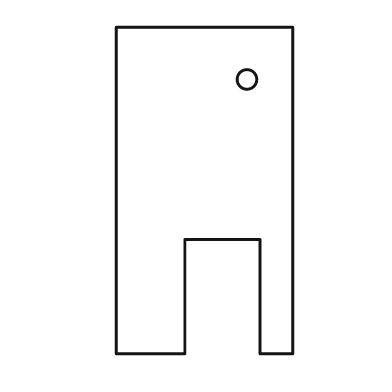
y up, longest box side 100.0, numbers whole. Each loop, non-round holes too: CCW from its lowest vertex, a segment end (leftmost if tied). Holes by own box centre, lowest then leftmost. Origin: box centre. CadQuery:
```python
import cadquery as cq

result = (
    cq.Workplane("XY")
    .moveTo(-27.0, -50.0)
    .lineTo(-6.0, -50.0)
    .lineTo(-6.0, -15.0)
    .lineTo(17.0, -15.0)
    .lineTo(17.0, -50.0)
    .lineTo(27.0, -50.0)
    .lineTo(27.0, 50.0)
    .lineTo(-27.0, 50.0)
    .close()
    .moveTo(13.0, 34.0)
    .circle(3.0)
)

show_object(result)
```